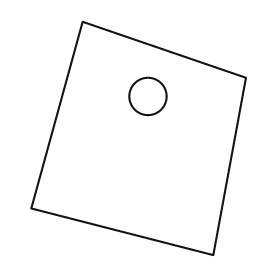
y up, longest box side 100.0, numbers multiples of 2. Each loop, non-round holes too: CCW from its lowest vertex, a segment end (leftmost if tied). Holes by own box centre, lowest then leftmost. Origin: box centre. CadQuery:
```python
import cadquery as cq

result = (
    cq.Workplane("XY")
    .moveTo(32.0, -50.0)
    .lineTo(46.0, 26.0)
    .lineTo(-24.0, 50.0)
    .lineTo(-46.0, -30.0)
    .close()
    .moveTo(4.0, 18.0)
    .circle(8.0)
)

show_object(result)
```